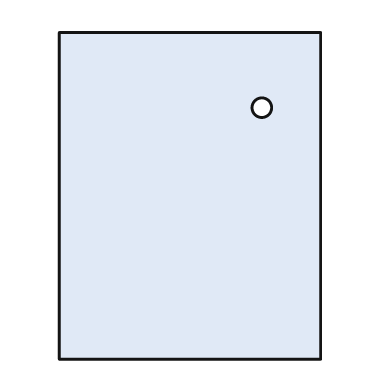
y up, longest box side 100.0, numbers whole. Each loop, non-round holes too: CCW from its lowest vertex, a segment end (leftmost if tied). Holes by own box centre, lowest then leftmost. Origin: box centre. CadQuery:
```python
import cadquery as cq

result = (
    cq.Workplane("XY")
    .moveTo(-40.0, -50.0)
    .lineTo(40.0, -50.0)
    .lineTo(40.0, 50.0)
    .lineTo(-40.0, 50.0)
    .close()
    .moveTo(22.0, 27.0)
    .circle(3.0)
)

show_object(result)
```